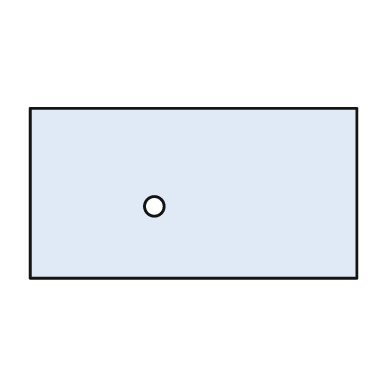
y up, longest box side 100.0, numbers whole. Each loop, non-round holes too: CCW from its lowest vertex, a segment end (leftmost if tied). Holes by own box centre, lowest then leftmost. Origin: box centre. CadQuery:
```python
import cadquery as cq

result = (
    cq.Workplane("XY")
    .moveTo(-50.0, -26.0)
    .lineTo(50.0, -26.0)
    .lineTo(50.0, 26.0)
    .lineTo(-50.0, 26.0)
    .close()
    .moveTo(-12.0, -4.0)
    .circle(3.0)
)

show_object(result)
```